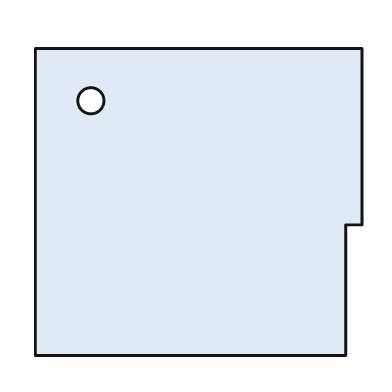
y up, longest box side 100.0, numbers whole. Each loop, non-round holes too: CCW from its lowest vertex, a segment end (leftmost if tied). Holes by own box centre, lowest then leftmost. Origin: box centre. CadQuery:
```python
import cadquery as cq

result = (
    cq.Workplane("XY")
    .moveTo(-50.0, -47.0)
    .lineTo(45.0, -47.0)
    .lineTo(45.0, -7.0)
    .lineTo(50.0, -7.0)
    .lineTo(50.0, 47.0)
    .lineTo(-50.0, 47.0)
    .close()
    .moveTo(-33.0, 31.0)
    .circle(4.0)
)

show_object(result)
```